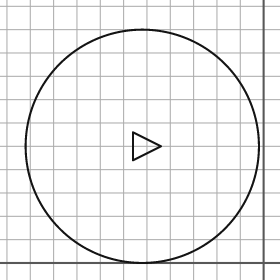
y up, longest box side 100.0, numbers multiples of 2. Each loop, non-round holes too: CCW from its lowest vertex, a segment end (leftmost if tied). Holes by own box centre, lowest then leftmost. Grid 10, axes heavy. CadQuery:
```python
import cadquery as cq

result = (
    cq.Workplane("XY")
    .moveTo(-52.0, 50.0)
    .circle(50.0)
    .moveTo(-56.0, 44.0)
    .lineTo(-44.0, 50.0)
    .lineTo(-56.0, 56.0)
    .close()
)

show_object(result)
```